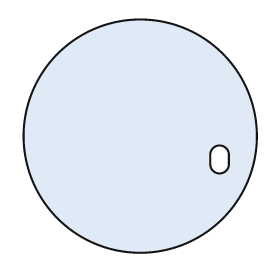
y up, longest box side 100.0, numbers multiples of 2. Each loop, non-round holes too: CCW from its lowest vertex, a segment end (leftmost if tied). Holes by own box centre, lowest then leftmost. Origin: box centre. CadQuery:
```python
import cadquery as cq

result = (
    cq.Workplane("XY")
    .moveTo(0.0, 0.0)
    .circle(50.0)
    .moveTo(30.0, -12.0)
    .threePointArc((34.0, -16.0), (38.0, -12.0))
    .lineTo(38.0, -8.0)
    .threePointArc((34.0, -4.0), (30.0, -8.0))
    .close()
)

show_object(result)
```